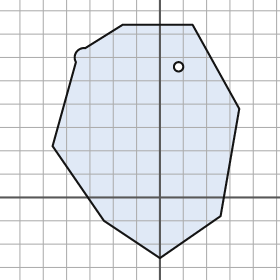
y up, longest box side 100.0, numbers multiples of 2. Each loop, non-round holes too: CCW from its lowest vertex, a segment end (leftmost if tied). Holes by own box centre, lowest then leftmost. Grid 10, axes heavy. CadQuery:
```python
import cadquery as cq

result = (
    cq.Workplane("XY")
    .moveTo(0.0, -26.0)
    .lineTo(26.0, -8.0)
    .lineTo(34.0, 38.0)
    .lineTo(14.0, 74.0)
    .lineTo(-16.0, 74.0)
    .lineTo(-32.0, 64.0)
    .threePointArc((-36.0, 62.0), (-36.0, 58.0))
    .lineTo(-46.0, 22.0)
    .lineTo(-24.0, -10.0)
    .close()
    .moveTo(8.0, 56.0)
    .circle(2.0)
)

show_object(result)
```